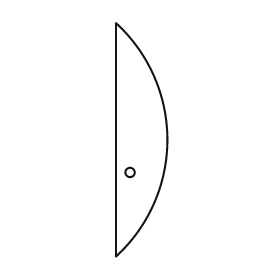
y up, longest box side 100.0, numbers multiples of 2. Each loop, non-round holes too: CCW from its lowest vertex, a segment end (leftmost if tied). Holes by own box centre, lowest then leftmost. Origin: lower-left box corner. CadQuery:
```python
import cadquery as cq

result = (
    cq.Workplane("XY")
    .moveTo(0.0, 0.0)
    .threePointArc((22.0, 50.0), (0.0, 100.0))
    .close()
    .moveTo(6.0, 36.0)
    .circle(2.0)
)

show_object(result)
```